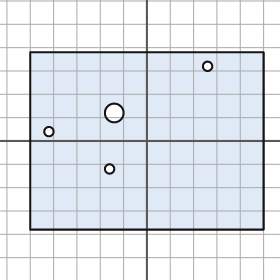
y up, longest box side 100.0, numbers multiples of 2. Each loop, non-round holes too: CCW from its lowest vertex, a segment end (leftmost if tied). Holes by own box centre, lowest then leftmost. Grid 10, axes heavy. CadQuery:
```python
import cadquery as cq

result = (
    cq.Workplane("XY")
    .moveTo(-50.0, -38.0)
    .lineTo(50.0, -38.0)
    .lineTo(50.0, 38.0)
    .lineTo(-50.0, 38.0)
    .close()
    .moveTo(-16.0, -12.0)
    .circle(2.0)
    .moveTo(-42.0, 4.0)
    .circle(2.0)
    .moveTo(-14.0, 12.0)
    .circle(4.0)
    .moveTo(26.0, 32.0)
    .circle(2.0)
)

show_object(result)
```